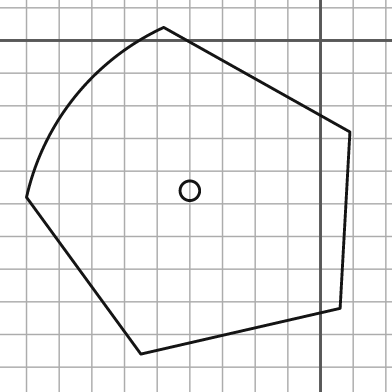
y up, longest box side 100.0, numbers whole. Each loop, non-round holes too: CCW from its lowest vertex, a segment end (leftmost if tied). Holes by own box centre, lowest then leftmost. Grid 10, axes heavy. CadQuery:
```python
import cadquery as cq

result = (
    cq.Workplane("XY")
    .moveTo(-55.0, -96.0)
    .lineTo(6.0, -82.0)
    .lineTo(9.0, -28.0)
    .lineTo(-48.0, 4.0)
    .threePointArc((-75.0, -17.0), (-90.0, -48.0))
    .close()
    .moveTo(-40.0, -46.0)
    .circle(3.0)
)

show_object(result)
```